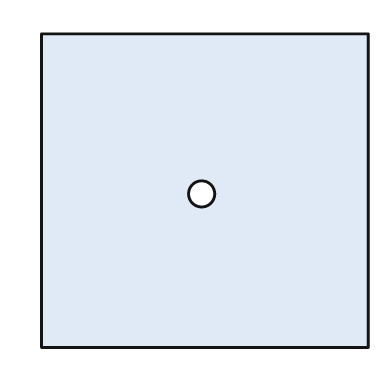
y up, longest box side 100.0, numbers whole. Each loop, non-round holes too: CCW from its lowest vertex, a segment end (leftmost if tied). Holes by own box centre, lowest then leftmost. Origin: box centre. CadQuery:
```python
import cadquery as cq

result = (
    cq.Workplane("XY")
    .moveTo(-50.0, -48.0)
    .lineTo(50.0, -48.0)
    .lineTo(50.0, 48.0)
    .lineTo(-50.0, 48.0)
    .close()
    .moveTo(-1.0, -1.0)
    .circle(4.0)
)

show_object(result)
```